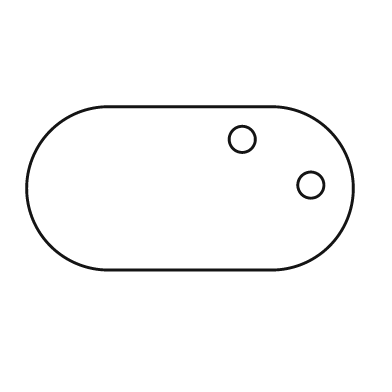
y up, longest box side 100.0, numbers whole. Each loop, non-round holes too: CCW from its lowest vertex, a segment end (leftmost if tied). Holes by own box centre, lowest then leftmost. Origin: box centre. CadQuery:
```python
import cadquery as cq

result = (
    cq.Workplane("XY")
    .moveTo(-25.0, -25.0)
    .lineTo(25.0, -25.0)
    .threePointArc((50.0, 0.0), (25.0, 25.0))
    .lineTo(-25.0, 25.0)
    .threePointArc((-50.0, 0.0), (-25.0, -25.0))
    .close()
    .moveTo(37.0, 1.0)
    .circle(4.0)
    .moveTo(16.0, 15.0)
    .circle(4.0)
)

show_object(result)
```